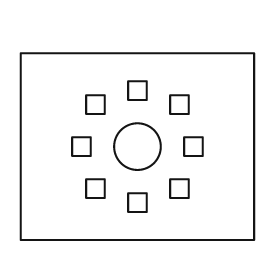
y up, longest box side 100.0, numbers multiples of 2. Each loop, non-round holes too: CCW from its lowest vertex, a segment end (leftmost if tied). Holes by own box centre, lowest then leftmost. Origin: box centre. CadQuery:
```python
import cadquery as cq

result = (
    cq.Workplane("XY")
    .moveTo(-50.0, -40.0)
    .lineTo(50.0, -40.0)
    .lineTo(50.0, 40.0)
    .lineTo(-50.0, 40.0)
    .close()
    .moveTo(-4.0, -28.0)
    .lineTo(4.0, -28.0)
    .lineTo(4.0, -20.0)
    .lineTo(-4.0, -20.0)
    .close()
    .moveTo(-22.0, -22.0)
    .lineTo(-14.0, -22.0)
    .lineTo(-14.0, -14.0)
    .lineTo(-22.0, -14.0)
    .close()
    .moveTo(14.0, -22.0)
    .lineTo(22.0, -22.0)
    .lineTo(22.0, -14.0)
    .lineTo(14.0, -14.0)
    .close()
    .moveTo(-28.0, -4.0)
    .lineTo(-20.0, -4.0)
    .lineTo(-20.0, 4.0)
    .lineTo(-28.0, 4.0)
    .close()
    .moveTo(0.0, 0.0)
    .circle(10.0)
    .moveTo(20.0, -4.0)
    .lineTo(28.0, -4.0)
    .lineTo(28.0, 4.0)
    .lineTo(20.0, 4.0)
    .close()
    .moveTo(-22.0, 14.0)
    .lineTo(-14.0, 14.0)
    .lineTo(-14.0, 22.0)
    .lineTo(-22.0, 22.0)
    .close()
    .moveTo(14.0, 14.0)
    .lineTo(22.0, 14.0)
    .lineTo(22.0, 22.0)
    .lineTo(14.0, 22.0)
    .close()
    .moveTo(-4.0, 20.0)
    .lineTo(4.0, 20.0)
    .lineTo(4.0, 28.0)
    .lineTo(-4.0, 28.0)
    .close()
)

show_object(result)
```